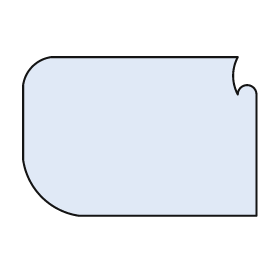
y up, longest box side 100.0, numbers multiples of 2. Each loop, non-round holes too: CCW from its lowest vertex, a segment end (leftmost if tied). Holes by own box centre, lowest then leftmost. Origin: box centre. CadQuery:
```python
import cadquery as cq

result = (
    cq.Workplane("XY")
    .moveTo(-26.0, -34.0)
    .lineTo(50.0, -34.0)
    .lineTo(50.0, 18.0)
    .threePointArc((46.0, 22.0), (42.0, 18.0))
    .threePointArc((40.0, 26.0), (42.0, 34.0))
    .lineTo(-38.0, 34.0)
    .threePointArc((-46.0, 30.0), (-50.0, 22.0))
    .lineTo(-50.0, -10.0)
    .threePointArc((-42.0, -26.0), (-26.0, -34.0))
    .close()
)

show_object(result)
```